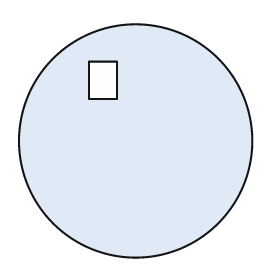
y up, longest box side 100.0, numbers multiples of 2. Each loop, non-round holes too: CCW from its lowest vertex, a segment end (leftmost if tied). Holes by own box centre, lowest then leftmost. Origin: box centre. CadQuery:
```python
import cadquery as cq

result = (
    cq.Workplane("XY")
    .moveTo(0.0, 0.0)
    .circle(50.0)
    .moveTo(-20.0, 18.0)
    .lineTo(-8.0, 18.0)
    .lineTo(-8.0, 34.0)
    .lineTo(-20.0, 34.0)
    .close()
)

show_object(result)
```